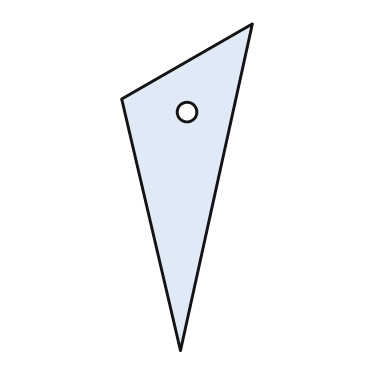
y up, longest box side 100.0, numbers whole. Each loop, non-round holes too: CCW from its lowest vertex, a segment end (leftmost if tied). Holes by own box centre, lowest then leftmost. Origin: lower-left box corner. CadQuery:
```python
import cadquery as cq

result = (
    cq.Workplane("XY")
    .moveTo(18.0, 0.0)
    .lineTo(40.0, 100.0)
    .lineTo(0.0, 77.0)
    .close()
    .moveTo(20.0, 73.0)
    .circle(3.0)
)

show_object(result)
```